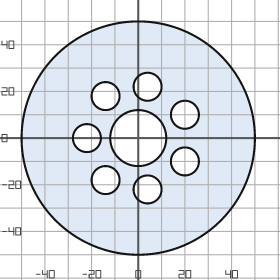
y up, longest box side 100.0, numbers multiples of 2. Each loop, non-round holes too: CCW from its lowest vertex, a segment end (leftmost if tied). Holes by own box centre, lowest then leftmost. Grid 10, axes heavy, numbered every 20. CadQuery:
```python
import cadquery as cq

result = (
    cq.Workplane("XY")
    .moveTo(0.0, 0.0)
    .circle(50.0)
    .moveTo(4.0, -22.0)
    .circle(6.0)
    .moveTo(-14.0, -18.0)
    .circle(6.0)
    .moveTo(20.0, -10.0)
    .circle(6.0)
    .moveTo(-22.0, 0.0)
    .circle(6.0)
    .moveTo(0.0, 0.0)
    .circle(12.0)
    .moveTo(20.0, 10.0)
    .circle(6.0)
    .moveTo(-14.0, 18.0)
    .circle(6.0)
    .moveTo(4.0, 22.0)
    .circle(6.0)
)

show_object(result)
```